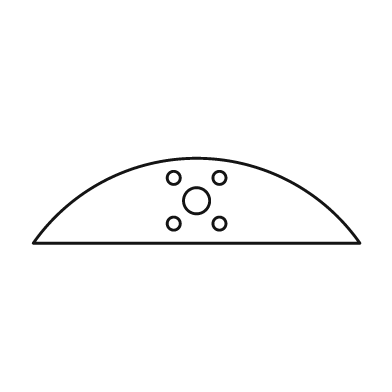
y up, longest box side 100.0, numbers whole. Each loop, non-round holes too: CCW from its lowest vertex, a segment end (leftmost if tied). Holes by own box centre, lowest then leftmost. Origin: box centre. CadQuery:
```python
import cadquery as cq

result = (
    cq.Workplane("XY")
    .moveTo(-50.0, -13.0)
    .lineTo(50.0, -13.0)
    .threePointArc((0.0, 13.0), (-50.0, -13.0))
    .close()
    .moveTo(-7.0, -7.0)
    .circle(2.0)
    .moveTo(7.0, -7.0)
    .circle(2.0)
    .moveTo(0.0, 0.0)
    .circle(4.0)
    .moveTo(-7.0, 7.0)
    .circle(2.0)
    .moveTo(7.0, 7.0)
    .circle(2.0)
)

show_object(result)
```